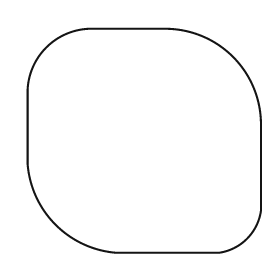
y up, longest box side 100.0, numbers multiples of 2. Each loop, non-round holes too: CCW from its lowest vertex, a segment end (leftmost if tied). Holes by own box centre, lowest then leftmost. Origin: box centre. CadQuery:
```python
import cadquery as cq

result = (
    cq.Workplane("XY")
    .moveTo(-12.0, -48.0)
    .lineTo(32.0, -48.0)
    .threePointArc((44.0, -42.0), (50.0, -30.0))
    .lineTo(50.0, 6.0)
    .threePointArc((38.0, 36.0), (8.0, 48.0))
    .lineTo(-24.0, 48.0)
    .threePointArc((-42.0, 40.0), (-50.0, 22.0))
    .lineTo(-50.0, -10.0)
    .threePointArc((-38.0, -36.0), (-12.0, -48.0))
    .close()
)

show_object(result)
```